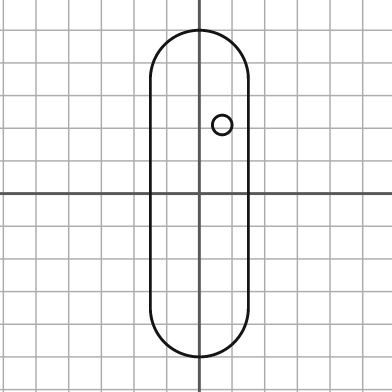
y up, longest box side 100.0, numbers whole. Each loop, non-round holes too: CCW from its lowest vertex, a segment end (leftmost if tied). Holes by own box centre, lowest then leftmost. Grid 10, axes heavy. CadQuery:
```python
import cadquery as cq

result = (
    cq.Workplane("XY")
    .moveTo(-15.0, -35.0)
    .threePointArc((0.0, -50.0), (15.0, -35.0))
    .lineTo(15.0, 35.0)
    .threePointArc((0.0, 50.0), (-15.0, 35.0))
    .close()
    .moveTo(7.0, 21.0)
    .circle(3.0)
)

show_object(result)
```